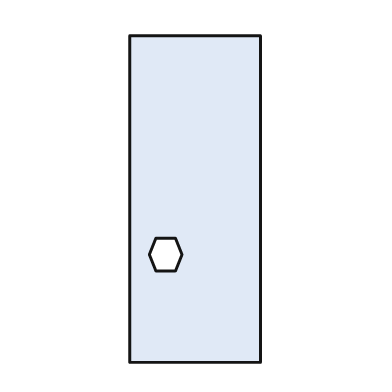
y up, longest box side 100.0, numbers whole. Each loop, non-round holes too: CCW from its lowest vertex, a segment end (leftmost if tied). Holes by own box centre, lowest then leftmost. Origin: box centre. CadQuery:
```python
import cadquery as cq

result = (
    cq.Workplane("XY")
    .moveTo(-20.0, -50.0)
    .lineTo(20.0, -50.0)
    .lineTo(20.0, 50.0)
    .lineTo(-20.0, 50.0)
    .close()
    .moveTo(-12.0, -22.0)
    .lineTo(-6.0, -22.0)
    .lineTo(-4.0, -17.0)
    .lineTo(-6.0, -12.0)
    .lineTo(-12.0, -12.0)
    .lineTo(-14.0, -17.0)
    .close()
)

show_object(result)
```